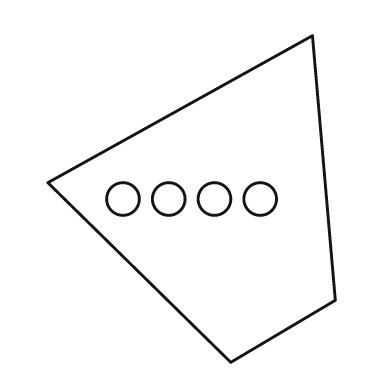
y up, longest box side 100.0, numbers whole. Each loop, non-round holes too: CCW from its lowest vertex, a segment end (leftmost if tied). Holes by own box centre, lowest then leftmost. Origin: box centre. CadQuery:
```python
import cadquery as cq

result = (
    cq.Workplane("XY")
    .moveTo(12.0, -50.0)
    .lineTo(44.0, -31.0)
    .lineTo(37.0, 50.0)
    .lineTo(-44.0, 5.0)
    .close()
    .moveTo(-21.0, 0.0)
    .circle(5.0)
    .moveTo(-7.0, 0.0)
    .circle(5.0)
    .moveTo(7.0, 0.0)
    .circle(5.0)
    .moveTo(21.0, 0.0)
    .circle(5.0)
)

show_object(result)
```